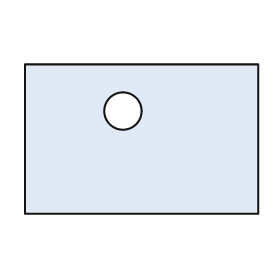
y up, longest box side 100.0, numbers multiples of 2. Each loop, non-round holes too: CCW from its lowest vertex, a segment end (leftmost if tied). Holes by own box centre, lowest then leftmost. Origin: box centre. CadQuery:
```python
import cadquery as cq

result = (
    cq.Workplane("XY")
    .moveTo(-50.0, -32.0)
    .lineTo(50.0, -32.0)
    .lineTo(50.0, 32.0)
    .lineTo(-50.0, 32.0)
    .close()
    .moveTo(-8.0, 12.0)
    .circle(8.0)
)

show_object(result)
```